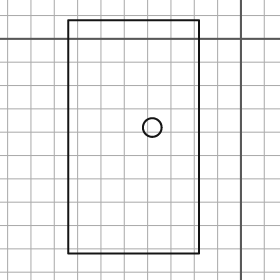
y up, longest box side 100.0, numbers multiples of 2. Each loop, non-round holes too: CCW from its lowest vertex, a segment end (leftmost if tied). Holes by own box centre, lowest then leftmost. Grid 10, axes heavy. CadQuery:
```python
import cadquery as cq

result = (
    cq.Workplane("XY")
    .moveTo(-74.0, -92.0)
    .lineTo(-18.0, -92.0)
    .lineTo(-18.0, 8.0)
    .lineTo(-74.0, 8.0)
    .close()
    .moveTo(-38.0, -38.0)
    .circle(4.0)
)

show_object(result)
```